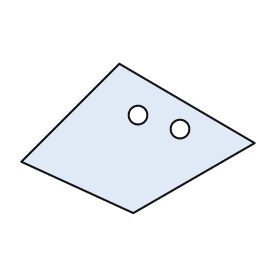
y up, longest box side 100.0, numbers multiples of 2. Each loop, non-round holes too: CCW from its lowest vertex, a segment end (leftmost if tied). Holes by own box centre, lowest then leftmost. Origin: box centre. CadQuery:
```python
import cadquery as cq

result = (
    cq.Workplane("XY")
    .moveTo(-2.0, -32.0)
    .lineTo(50.0, -2.0)
    .lineTo(-8.0, 32.0)
    .lineTo(-50.0, -10.0)
    .close()
    .moveTo(18.0, 4.0)
    .circle(4.0)
    .moveTo(0.0, 10.0)
    .circle(4.0)
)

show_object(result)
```